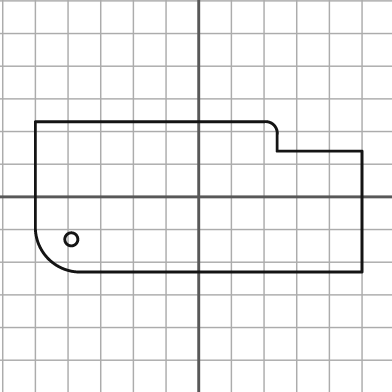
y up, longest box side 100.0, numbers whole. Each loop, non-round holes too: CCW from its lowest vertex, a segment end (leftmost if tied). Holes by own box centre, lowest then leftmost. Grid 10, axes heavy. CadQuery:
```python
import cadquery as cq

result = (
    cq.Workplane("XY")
    .moveTo(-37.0, -23.0)
    .lineTo(50.0, -23.0)
    .lineTo(50.0, 14.0)
    .lineTo(24.0, 14.0)
    .lineTo(24.0, 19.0)
    .threePointArc((23.0, 22.0), (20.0, 23.0))
    .lineTo(-50.0, 23.0)
    .lineTo(-50.0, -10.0)
    .threePointArc((-46.0, -19.0), (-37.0, -23.0))
    .close()
    .moveTo(-39.0, -13.0)
    .circle(2.0)
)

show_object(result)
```